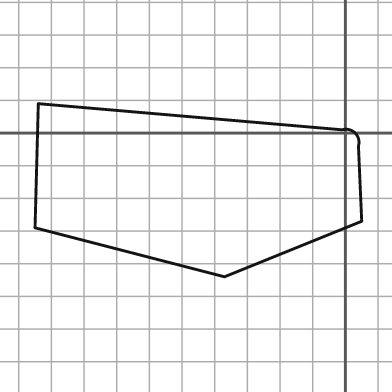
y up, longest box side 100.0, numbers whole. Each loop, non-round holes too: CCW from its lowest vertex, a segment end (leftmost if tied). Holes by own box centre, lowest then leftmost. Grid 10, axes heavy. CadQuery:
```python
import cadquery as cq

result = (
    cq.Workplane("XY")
    .moveTo(-37.0, -44.0)
    .lineTo(5.0, -27.0)
    .lineTo(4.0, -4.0)
    .threePointArc((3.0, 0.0), (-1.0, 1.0))
    .lineTo(-94.0, 9.0)
    .lineTo(-95.0, -29.0)
    .close()
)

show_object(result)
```